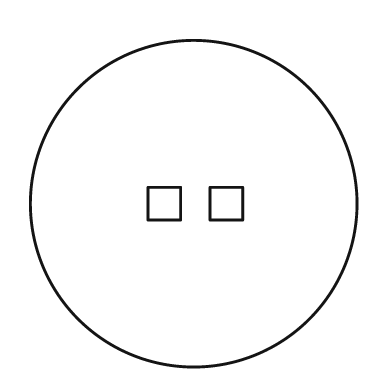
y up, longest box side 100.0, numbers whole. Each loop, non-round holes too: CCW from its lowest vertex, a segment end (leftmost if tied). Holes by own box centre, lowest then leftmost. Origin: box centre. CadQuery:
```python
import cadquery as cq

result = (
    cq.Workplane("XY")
    .moveTo(0.0, 0.0)
    .circle(50.0)
    .moveTo(-14.0, -5.0)
    .lineTo(-4.0, -5.0)
    .lineTo(-4.0, 5.0)
    .lineTo(-14.0, 5.0)
    .close()
    .moveTo(5.0, -5.0)
    .lineTo(15.0, -5.0)
    .lineTo(15.0, 5.0)
    .lineTo(5.0, 5.0)
    .close()
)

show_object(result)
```